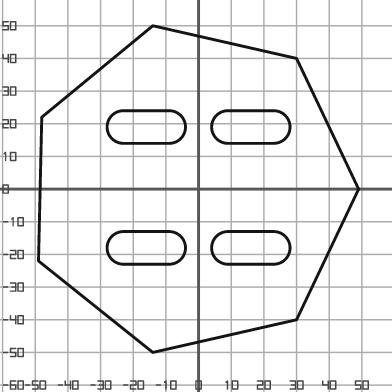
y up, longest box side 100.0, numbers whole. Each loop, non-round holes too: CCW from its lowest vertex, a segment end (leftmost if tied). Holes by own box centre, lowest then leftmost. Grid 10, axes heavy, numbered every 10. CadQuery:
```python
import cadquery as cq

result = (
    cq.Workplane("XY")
    .moveTo(-14.0, -50.0)
    .lineTo(30.0, -40.0)
    .lineTo(49.0, 0.0)
    .lineTo(30.0, 40.0)
    .lineTo(-14.0, 50.0)
    .lineTo(-48.0, 22.0)
    .lineTo(-49.0, -22.0)
    .close()
    .moveTo(-23.0, -23.0)
    .lineTo(-9.0, -23.0)
    .threePointArc((-4.0, -18.0), (-9.0, -13.0))
    .lineTo(-23.0, -13.0)
    .threePointArc((-28.0, -18.0), (-23.0, -23.0))
    .close()
    .moveTo(9.0, -23.0)
    .lineTo(23.0, -23.0)
    .threePointArc((28.0, -18.0), (23.0, -13.0))
    .lineTo(9.0, -13.0)
    .threePointArc((4.0, -18.0), (9.0, -23.0))
    .close()
    .moveTo(-23.0, 14.0)
    .lineTo(-9.0, 14.0)
    .threePointArc((-4.0, 19.0), (-9.0, 24.0))
    .lineTo(-23.0, 24.0)
    .threePointArc((-28.0, 19.0), (-23.0, 14.0))
    .close()
    .moveTo(9.0, 14.0)
    .lineTo(23.0, 14.0)
    .threePointArc((28.0, 19.0), (23.0, 24.0))
    .lineTo(9.0, 24.0)
    .threePointArc((4.0, 19.0), (9.0, 14.0))
    .close()
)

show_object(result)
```